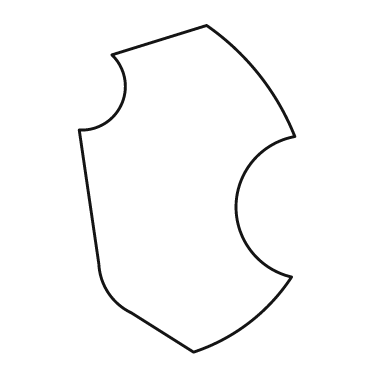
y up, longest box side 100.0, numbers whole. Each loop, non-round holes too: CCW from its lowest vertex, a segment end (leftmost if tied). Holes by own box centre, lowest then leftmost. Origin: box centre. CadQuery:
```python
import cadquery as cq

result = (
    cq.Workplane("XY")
    .moveTo(2.0, -50.0)
    .threePointArc((19.0, -41.0), (32.0, -27.0))
    .threePointArc((15.0, -5.0), (33.0, 16.0))
    .threePointArc((22.0, 35.0), (6.0, 50.0))
    .lineTo(-23.0, 41.0)
    .threePointArc((-20.0, 26.0), (-33.0, 18.0))
    .lineTo(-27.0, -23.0)
    .threePointArc((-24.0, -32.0), (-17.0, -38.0))
    .close()
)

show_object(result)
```